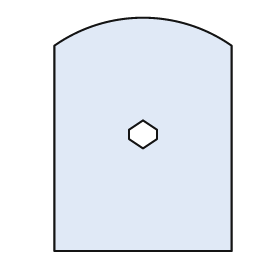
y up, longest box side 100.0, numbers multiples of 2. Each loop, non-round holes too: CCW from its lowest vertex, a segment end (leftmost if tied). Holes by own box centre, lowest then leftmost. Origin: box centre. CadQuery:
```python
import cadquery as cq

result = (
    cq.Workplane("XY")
    .moveTo(-38.0, -50.0)
    .lineTo(38.0, -50.0)
    .lineTo(38.0, 38.0)
    .threePointArc((0.0, 50.0), (-38.0, 38.0))
    .close()
    .moveTo(0.0, -6.0)
    .lineTo(6.0, -2.0)
    .lineTo(6.0, 2.0)
    .lineTo(0.0, 6.0)
    .lineTo(-6.0, 2.0)
    .lineTo(-6.0, -2.0)
    .close()
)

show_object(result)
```